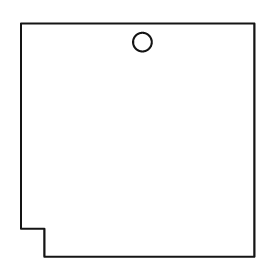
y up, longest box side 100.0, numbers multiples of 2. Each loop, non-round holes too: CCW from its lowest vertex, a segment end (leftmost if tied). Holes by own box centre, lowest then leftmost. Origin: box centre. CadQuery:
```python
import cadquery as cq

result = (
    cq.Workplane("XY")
    .moveTo(-40.0, -50.0)
    .lineTo(50.0, -50.0)
    .lineTo(50.0, 50.0)
    .lineTo(-50.0, 50.0)
    .lineTo(-50.0, -38.0)
    .lineTo(-40.0, -38.0)
    .close()
    .moveTo(2.0, 42.0)
    .circle(4.0)
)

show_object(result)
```